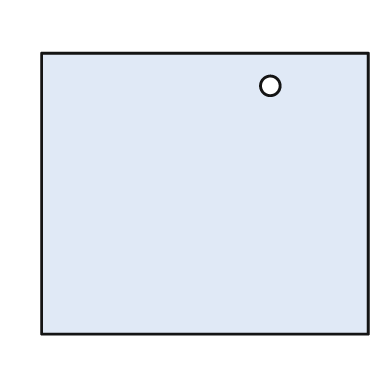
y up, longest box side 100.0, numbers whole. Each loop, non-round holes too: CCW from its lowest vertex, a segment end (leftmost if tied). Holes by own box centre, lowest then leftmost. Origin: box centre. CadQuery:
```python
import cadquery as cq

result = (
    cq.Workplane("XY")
    .moveTo(-50.0, -43.0)
    .lineTo(50.0, -43.0)
    .lineTo(50.0, 43.0)
    .lineTo(-50.0, 43.0)
    .close()
    .moveTo(20.0, 33.0)
    .circle(3.0)
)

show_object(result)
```